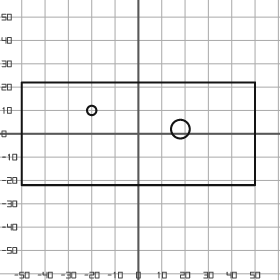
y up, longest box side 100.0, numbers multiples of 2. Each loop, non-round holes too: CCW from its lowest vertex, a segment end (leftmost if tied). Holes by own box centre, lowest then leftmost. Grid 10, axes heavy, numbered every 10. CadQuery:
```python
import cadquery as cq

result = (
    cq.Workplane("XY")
    .moveTo(-50.0, -22.0)
    .lineTo(50.0, -22.0)
    .lineTo(50.0, 22.0)
    .lineTo(-50.0, 22.0)
    .close()
    .moveTo(18.0, 2.0)
    .circle(4.0)
    .moveTo(-20.0, 10.0)
    .circle(2.0)
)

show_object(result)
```